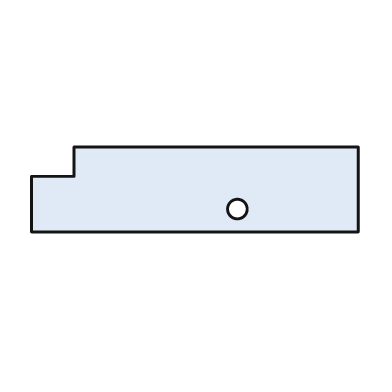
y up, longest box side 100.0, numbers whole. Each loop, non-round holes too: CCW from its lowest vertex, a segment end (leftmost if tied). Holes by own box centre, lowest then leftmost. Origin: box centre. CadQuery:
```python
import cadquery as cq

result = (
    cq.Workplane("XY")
    .moveTo(-50.0, -13.0)
    .lineTo(50.0, -13.0)
    .lineTo(50.0, 13.0)
    .lineTo(-37.0, 13.0)
    .lineTo(-37.0, 4.0)
    .lineTo(-50.0, 4.0)
    .close()
    .moveTo(13.0, -6.0)
    .circle(3.0)
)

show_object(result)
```